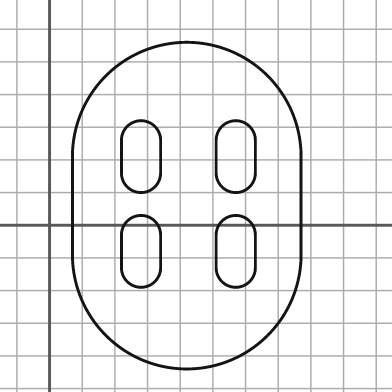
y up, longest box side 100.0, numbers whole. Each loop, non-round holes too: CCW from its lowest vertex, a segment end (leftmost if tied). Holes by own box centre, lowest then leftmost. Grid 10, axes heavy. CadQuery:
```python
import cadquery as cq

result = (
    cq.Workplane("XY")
    .moveTo(7.0, -9.0)
    .threePointArc((42.0, -44.0), (77.0, -9.0))
    .lineTo(77.0, 21.0)
    .threePointArc((42.0, 56.0), (7.0, 21.0))
    .close()
    .moveTo(22.0, -13.0)
    .threePointArc((28.0, -19.0), (34.0, -13.0))
    .lineTo(34.0, -3.0)
    .threePointArc((28.0, 3.0), (22.0, -3.0))
    .close()
    .moveTo(51.0, -13.0)
    .threePointArc((57.0, -19.0), (63.0, -13.0))
    .lineTo(63.0, -3.0)
    .threePointArc((57.0, 3.0), (51.0, -3.0))
    .close()
    .moveTo(22.0, 16.0)
    .threePointArc((28.0, 10.0), (34.0, 16.0))
    .lineTo(34.0, 26.0)
    .threePointArc((28.0, 32.0), (22.0, 26.0))
    .close()
    .moveTo(51.0, 16.0)
    .threePointArc((57.0, 10.0), (63.0, 16.0))
    .lineTo(63.0, 26.0)
    .threePointArc((57.0, 32.0), (51.0, 26.0))
    .close()
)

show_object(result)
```